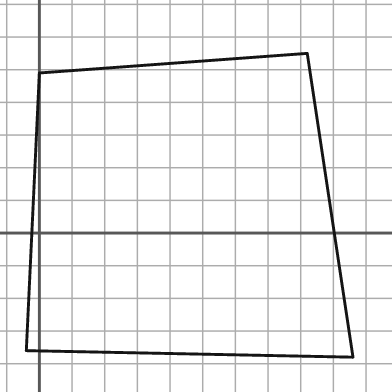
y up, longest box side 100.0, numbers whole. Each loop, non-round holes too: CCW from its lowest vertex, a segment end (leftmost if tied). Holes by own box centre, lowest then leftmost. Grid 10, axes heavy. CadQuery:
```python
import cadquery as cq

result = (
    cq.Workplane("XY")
    .moveTo(96.0, -38.0)
    .lineTo(82.0, 55.0)
    .lineTo(0.0, 49.0)
    .lineTo(-4.0, -36.0)
    .close()
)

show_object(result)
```